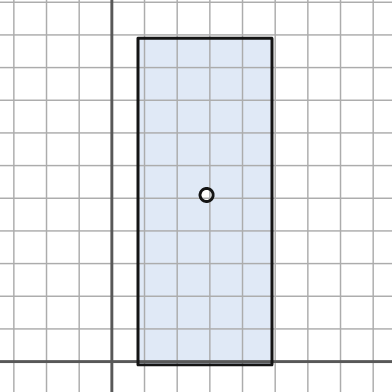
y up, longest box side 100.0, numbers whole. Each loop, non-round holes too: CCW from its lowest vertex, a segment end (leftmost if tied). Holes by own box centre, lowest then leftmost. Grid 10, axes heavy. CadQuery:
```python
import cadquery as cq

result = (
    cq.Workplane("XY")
    .moveTo(8.0, -1.0)
    .lineTo(49.0, -1.0)
    .lineTo(49.0, 99.0)
    .lineTo(8.0, 99.0)
    .close()
    .moveTo(29.0, 51.0)
    .circle(2.0)
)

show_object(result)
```